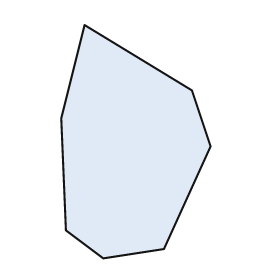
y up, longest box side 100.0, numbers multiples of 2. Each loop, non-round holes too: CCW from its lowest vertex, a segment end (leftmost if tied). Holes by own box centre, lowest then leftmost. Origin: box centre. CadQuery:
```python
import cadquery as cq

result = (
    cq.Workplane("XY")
    .moveTo(-14.0, -50.0)
    .lineTo(12.0, -46.0)
    .lineTo(32.0, -2.0)
    .lineTo(24.0, 22.0)
    .lineTo(-22.0, 50.0)
    .lineTo(-32.0, 10.0)
    .lineTo(-30.0, -38.0)
    .close()
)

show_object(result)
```